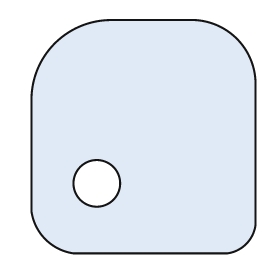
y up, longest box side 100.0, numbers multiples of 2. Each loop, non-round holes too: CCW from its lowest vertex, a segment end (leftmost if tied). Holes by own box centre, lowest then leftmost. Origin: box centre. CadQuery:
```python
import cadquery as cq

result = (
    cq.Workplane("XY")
    .moveTo(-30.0, -50.0)
    .lineTo(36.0, -50.0)
    .threePointArc((44.0, -46.0), (48.0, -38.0))
    .lineTo(48.0, 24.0)
    .threePointArc((40.0, 42.0), (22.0, 50.0))
    .lineTo(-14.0, 50.0)
    .threePointArc((-38.0, 40.0), (-48.0, 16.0))
    .lineTo(-48.0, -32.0)
    .threePointArc((-42.0, -44.0), (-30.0, -50.0))
    .close()
    .moveTo(-20.0, -20.0)
    .circle(10.0)
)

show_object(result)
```